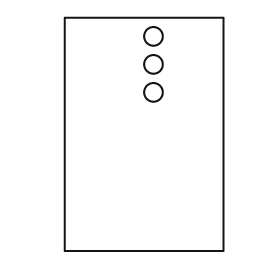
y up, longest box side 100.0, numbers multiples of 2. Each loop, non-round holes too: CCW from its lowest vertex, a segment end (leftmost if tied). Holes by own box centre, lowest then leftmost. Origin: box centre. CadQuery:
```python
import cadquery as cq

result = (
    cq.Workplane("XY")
    .moveTo(-34.0, -50.0)
    .lineTo(34.0, -50.0)
    .lineTo(34.0, 50.0)
    .lineTo(-34.0, 50.0)
    .close()
    .moveTo(4.0, 18.0)
    .circle(4.0)
    .moveTo(4.0, 30.0)
    .circle(4.0)
    .moveTo(4.0, 42.0)
    .circle(4.0)
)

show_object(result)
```